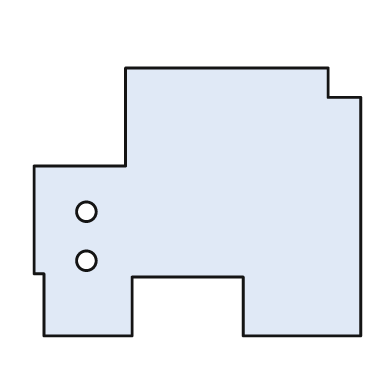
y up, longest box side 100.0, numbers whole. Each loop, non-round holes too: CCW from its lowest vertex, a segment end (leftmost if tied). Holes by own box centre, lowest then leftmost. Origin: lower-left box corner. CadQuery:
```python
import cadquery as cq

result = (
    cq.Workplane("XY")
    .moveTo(3.0, 0.0)
    .lineTo(30.0, 0.0)
    .lineTo(30.0, 18.0)
    .lineTo(64.0, 18.0)
    .lineTo(64.0, 0.0)
    .lineTo(100.0, 0.0)
    .lineTo(100.0, 73.0)
    .lineTo(90.0, 73.0)
    .lineTo(90.0, 82.0)
    .lineTo(28.0, 82.0)
    .lineTo(28.0, 52.0)
    .lineTo(0.0, 52.0)
    .lineTo(0.0, 19.0)
    .lineTo(3.0, 19.0)
    .close()
    .moveTo(16.0, 23.0)
    .circle(3.0)
    .moveTo(16.0, 38.0)
    .circle(3.0)
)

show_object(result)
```